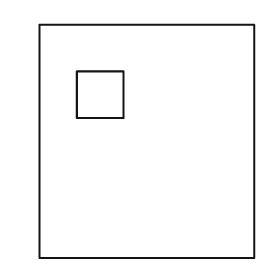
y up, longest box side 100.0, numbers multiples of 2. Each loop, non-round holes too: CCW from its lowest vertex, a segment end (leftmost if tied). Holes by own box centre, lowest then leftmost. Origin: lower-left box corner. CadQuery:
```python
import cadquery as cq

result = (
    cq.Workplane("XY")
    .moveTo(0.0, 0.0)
    .lineTo(92.0, 0.0)
    .lineTo(92.0, 100.0)
    .lineTo(0.0, 100.0)
    .close()
    .moveTo(16.0, 60.0)
    .lineTo(36.0, 60.0)
    .lineTo(36.0, 80.0)
    .lineTo(16.0, 80.0)
    .close()
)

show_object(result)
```